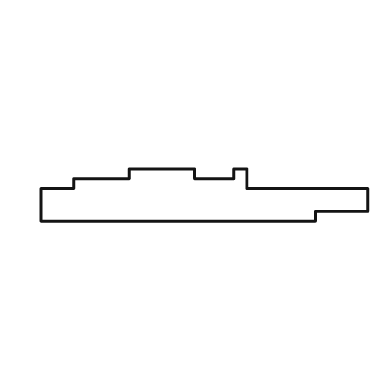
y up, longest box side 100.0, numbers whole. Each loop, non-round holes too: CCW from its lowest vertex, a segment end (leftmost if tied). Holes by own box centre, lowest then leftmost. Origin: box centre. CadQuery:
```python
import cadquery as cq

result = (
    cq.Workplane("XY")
    .moveTo(-50.0, -8.0)
    .lineTo(34.0, -8.0)
    .lineTo(34.0, -5.0)
    .lineTo(50.0, -5.0)
    .lineTo(50.0, 2.0)
    .lineTo(13.0, 2.0)
    .lineTo(13.0, 8.0)
    .lineTo(9.0, 8.0)
    .lineTo(9.0, 5.0)
    .lineTo(-3.0, 5.0)
    .lineTo(-3.0, 8.0)
    .lineTo(-23.0, 8.0)
    .lineTo(-23.0, 5.0)
    .lineTo(-40.0, 5.0)
    .lineTo(-40.0, 2.0)
    .lineTo(-50.0, 2.0)
    .close()
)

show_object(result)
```